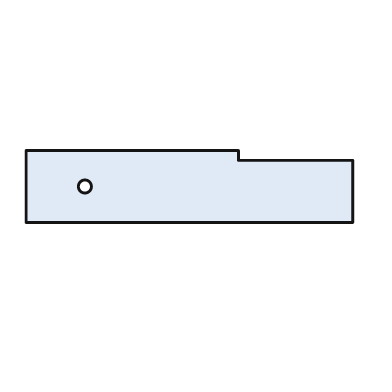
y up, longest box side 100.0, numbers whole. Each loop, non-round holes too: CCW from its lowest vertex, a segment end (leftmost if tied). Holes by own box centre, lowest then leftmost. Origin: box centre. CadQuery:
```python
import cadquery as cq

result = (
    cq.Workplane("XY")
    .moveTo(-50.0, -11.0)
    .lineTo(50.0, -11.0)
    .lineTo(50.0, 8.0)
    .lineTo(15.0, 8.0)
    .lineTo(15.0, 11.0)
    .lineTo(-50.0, 11.0)
    .close()
    .moveTo(-32.0, 0.0)
    .circle(2.0)
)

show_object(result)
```